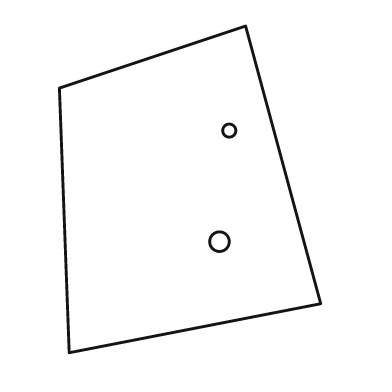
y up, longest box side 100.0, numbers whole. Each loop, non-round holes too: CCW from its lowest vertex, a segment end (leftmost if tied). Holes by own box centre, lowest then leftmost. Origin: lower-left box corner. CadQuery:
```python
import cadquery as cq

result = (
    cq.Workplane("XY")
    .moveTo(3.0, 0.0)
    .lineTo(80.0, 15.0)
    .lineTo(57.0, 100.0)
    .lineTo(0.0, 81.0)
    .close()
    .moveTo(49.0, 34.0)
    .circle(3.0)
    .moveTo(52.0, 68.0)
    .circle(2.0)
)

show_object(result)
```